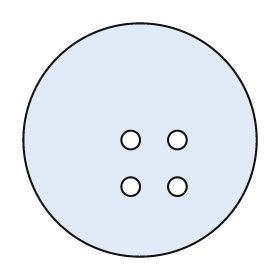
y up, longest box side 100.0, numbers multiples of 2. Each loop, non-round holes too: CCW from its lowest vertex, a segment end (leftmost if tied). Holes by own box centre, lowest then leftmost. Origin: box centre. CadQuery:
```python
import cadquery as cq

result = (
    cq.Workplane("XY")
    .moveTo(0.0, 0.0)
    .circle(50.0)
    .moveTo(-4.0, -20.0)
    .circle(4.0)
    .moveTo(16.0, -20.0)
    .circle(4.0)
    .moveTo(-4.0, 0.0)
    .circle(4.0)
    .moveTo(16.0, 0.0)
    .circle(4.0)
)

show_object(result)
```